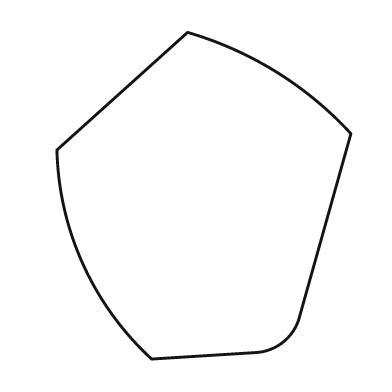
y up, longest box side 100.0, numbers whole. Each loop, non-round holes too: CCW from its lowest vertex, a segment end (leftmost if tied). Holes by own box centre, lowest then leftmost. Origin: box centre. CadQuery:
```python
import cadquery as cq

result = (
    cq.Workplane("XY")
    .moveTo(-16.0, -50.0)
    .lineTo(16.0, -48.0)
    .threePointArc((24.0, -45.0), (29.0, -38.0))
    .lineTo(45.0, 19.0)
    .threePointArc((22.0, 38.0), (-5.0, 50.0))
    .lineTo(-45.0, 14.0)
    .threePointArc((-37.0, -21.0), (-16.0, -50.0))
    .close()
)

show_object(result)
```